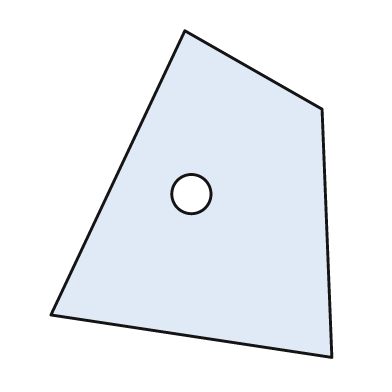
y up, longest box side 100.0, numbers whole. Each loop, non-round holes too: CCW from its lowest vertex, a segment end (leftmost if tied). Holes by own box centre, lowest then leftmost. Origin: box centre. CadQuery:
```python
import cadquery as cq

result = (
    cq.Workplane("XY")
    .moveTo(43.0, -50.0)
    .lineTo(40.0, 26.0)
    .lineTo(-2.0, 50.0)
    .lineTo(-43.0, -37.0)
    .close()
    .moveTo(0.0, 0.0)
    .circle(6.0)
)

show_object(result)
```